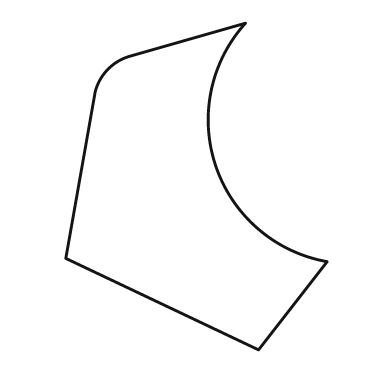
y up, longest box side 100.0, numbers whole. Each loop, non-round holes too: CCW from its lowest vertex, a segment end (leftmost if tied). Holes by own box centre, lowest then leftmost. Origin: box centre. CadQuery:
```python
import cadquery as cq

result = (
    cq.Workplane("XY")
    .moveTo(19.0, -50.0)
    .lineTo(40.0, -23.0)
    .threePointArc((6.0, 6.0), (15.0, 50.0))
    .lineTo(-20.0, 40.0)
    .threePointArc((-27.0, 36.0), (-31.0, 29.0))
    .lineTo(-40.0, -22.0)
    .close()
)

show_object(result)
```